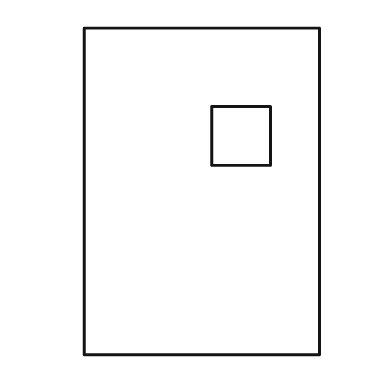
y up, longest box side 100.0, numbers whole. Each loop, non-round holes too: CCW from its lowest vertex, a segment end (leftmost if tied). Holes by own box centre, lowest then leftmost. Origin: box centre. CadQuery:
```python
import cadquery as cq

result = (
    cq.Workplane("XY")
    .moveTo(-36.0, -50.0)
    .lineTo(36.0, -50.0)
    .lineTo(36.0, 50.0)
    .lineTo(-36.0, 50.0)
    .close()
    .moveTo(3.0, 8.0)
    .lineTo(21.0, 8.0)
    .lineTo(21.0, 26.0)
    .lineTo(3.0, 26.0)
    .close()
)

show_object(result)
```